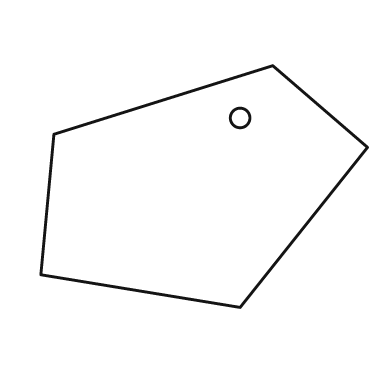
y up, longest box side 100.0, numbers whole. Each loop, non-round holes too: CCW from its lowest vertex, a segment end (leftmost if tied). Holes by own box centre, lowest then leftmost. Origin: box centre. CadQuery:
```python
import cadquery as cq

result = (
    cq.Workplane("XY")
    .moveTo(11.0, -37.0)
    .lineTo(50.0, 12.0)
    .lineTo(21.0, 37.0)
    .lineTo(-46.0, 16.0)
    .lineTo(-50.0, -27.0)
    .close()
    .moveTo(11.0, 21.0)
    .circle(3.0)
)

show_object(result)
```